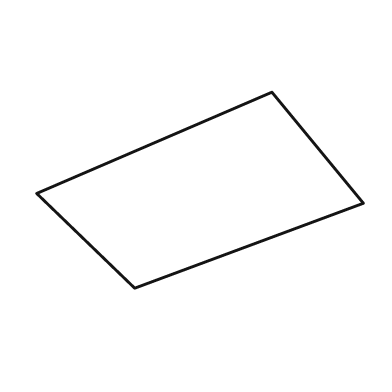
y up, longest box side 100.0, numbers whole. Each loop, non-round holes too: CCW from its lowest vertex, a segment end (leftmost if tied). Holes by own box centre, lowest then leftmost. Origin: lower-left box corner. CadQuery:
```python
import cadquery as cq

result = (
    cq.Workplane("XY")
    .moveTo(30.0, 0.0)
    .lineTo(100.0, 26.0)
    .lineTo(72.0, 60.0)
    .lineTo(0.0, 29.0)
    .close()
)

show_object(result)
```